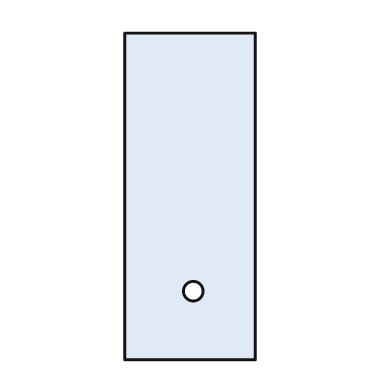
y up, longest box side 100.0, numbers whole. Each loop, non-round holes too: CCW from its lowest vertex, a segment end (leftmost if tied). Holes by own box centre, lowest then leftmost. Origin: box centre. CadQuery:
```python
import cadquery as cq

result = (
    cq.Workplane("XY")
    .moveTo(-20.0, -50.0)
    .lineTo(20.0, -50.0)
    .lineTo(20.0, 50.0)
    .lineTo(-20.0, 50.0)
    .close()
    .moveTo(1.0, -29.0)
    .circle(3.0)
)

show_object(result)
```